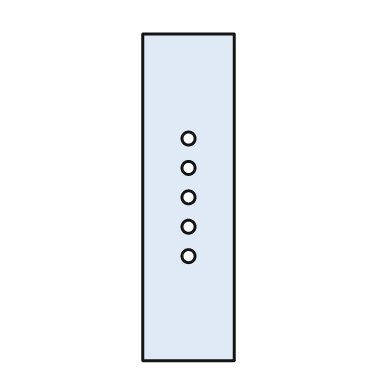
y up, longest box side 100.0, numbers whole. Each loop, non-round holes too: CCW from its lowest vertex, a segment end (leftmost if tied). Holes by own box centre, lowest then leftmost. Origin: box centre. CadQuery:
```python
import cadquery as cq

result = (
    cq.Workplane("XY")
    .moveTo(-14.0, -50.0)
    .lineTo(14.0, -50.0)
    .lineTo(14.0, 50.0)
    .lineTo(-14.0, 50.0)
    .close()
    .moveTo(0.0, -18.0)
    .circle(2.0)
    .moveTo(0.0, -9.0)
    .circle(2.0)
    .moveTo(0.0, 0.0)
    .circle(2.0)
    .moveTo(0.0, 9.0)
    .circle(2.0)
    .moveTo(0.0, 18.0)
    .circle(2.0)
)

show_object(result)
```